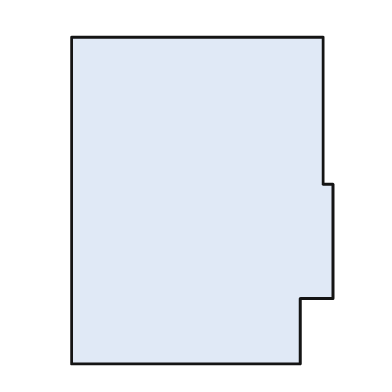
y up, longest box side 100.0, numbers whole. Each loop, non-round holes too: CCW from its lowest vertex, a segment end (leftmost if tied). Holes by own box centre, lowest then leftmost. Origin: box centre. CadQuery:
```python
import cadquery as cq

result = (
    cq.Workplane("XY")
    .moveTo(-40.0, -50.0)
    .lineTo(30.0, -50.0)
    .lineTo(30.0, -30.0)
    .lineTo(40.0, -30.0)
    .lineTo(40.0, 5.0)
    .lineTo(37.0, 5.0)
    .lineTo(37.0, 50.0)
    .lineTo(-40.0, 50.0)
    .close()
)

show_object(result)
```